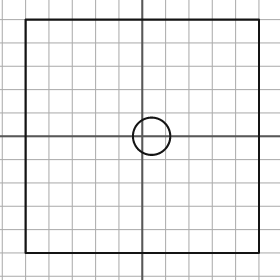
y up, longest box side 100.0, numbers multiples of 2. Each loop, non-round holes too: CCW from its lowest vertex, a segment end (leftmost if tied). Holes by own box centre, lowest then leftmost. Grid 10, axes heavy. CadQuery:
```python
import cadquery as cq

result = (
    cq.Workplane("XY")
    .moveTo(-50.0, -50.0)
    .lineTo(50.0, -50.0)
    .lineTo(50.0, 50.0)
    .lineTo(-50.0, 50.0)
    .close()
    .moveTo(4.0, 0.0)
    .circle(8.0)
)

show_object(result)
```